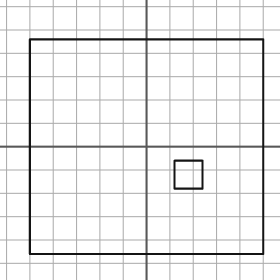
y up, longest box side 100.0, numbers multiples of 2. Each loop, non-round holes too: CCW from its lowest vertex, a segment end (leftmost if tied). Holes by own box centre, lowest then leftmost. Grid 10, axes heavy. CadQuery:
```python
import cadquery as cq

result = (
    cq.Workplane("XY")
    .moveTo(-50.0, -46.0)
    .lineTo(50.0, -46.0)
    .lineTo(50.0, 46.0)
    .lineTo(-50.0, 46.0)
    .close()
    .moveTo(12.0, -18.0)
    .lineTo(24.0, -18.0)
    .lineTo(24.0, -6.0)
    .lineTo(12.0, -6.0)
    .close()
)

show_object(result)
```